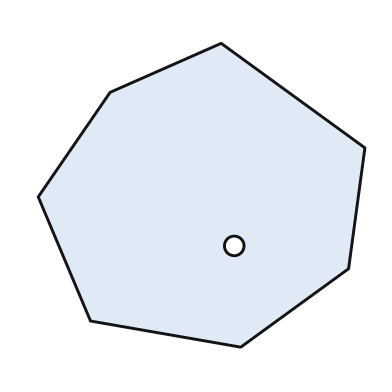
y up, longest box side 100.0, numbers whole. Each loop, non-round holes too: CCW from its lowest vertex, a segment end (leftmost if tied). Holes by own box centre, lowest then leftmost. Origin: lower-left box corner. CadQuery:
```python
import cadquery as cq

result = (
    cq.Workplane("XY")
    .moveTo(62.0, 0.0)
    .lineTo(95.0, 24.0)
    .lineTo(100.0, 61.0)
    .lineTo(56.0, 93.0)
    .lineTo(22.0, 78.0)
    .lineTo(0.0, 46.0)
    .lineTo(16.0, 8.0)
    .close()
    .moveTo(60.0, 31.0)
    .circle(3.0)
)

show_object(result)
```